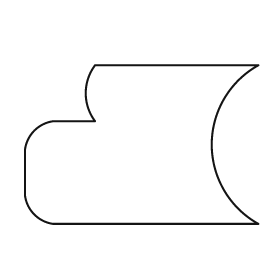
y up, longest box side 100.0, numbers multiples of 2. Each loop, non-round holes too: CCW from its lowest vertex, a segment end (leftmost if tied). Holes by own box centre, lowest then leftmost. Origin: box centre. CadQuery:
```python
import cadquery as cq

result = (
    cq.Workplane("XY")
    .moveTo(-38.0, -34.0)
    .lineTo(50.0, -34.0)
    .threePointArc((30.0, 0.0), (50.0, 34.0))
    .lineTo(-20.0, 34.0)
    .threePointArc((-24.0, 22.0), (-20.0, 10.0))
    .lineTo(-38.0, 10.0)
    .threePointArc((-46.0, 6.0), (-50.0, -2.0))
    .lineTo(-50.0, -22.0)
    .threePointArc((-46.0, -30.0), (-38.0, -34.0))
    .close()
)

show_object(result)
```